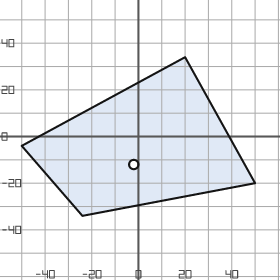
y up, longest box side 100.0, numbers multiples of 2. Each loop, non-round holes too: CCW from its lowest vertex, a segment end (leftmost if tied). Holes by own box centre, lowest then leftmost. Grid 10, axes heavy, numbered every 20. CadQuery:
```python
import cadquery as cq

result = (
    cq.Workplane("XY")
    .moveTo(-24.0, -34.0)
    .lineTo(50.0, -20.0)
    .lineTo(20.0, 34.0)
    .lineTo(-50.0, -4.0)
    .close()
    .moveTo(-2.0, -12.0)
    .circle(2.0)
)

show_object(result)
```